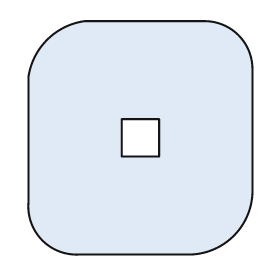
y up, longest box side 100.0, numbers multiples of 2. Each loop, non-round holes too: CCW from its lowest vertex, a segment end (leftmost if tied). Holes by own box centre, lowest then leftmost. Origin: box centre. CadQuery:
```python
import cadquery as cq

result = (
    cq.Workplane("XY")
    .moveTo(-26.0, -50.0)
    .lineTo(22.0, -50.0)
    .threePointArc((40.0, -42.0), (48.0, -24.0))
    .lineTo(48.0, 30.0)
    .threePointArc((42.0, 44.0), (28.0, 50.0))
    .lineTo(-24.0, 50.0)
    .threePointArc((-40.0, 42.0), (-48.0, 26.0))
    .lineTo(-48.0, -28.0)
    .threePointArc((-42.0, -44.0), (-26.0, -50.0))
    .close()
    .moveTo(-8.0, -8.0)
    .lineTo(8.0, -8.0)
    .lineTo(8.0, 8.0)
    .lineTo(-8.0, 8.0)
    .close()
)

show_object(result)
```